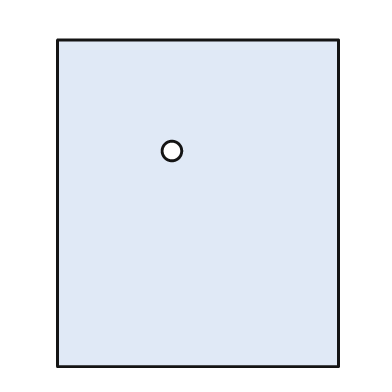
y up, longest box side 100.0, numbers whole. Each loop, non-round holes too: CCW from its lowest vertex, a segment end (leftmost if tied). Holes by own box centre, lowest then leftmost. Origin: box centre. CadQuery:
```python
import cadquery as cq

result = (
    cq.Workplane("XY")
    .moveTo(-43.0, -50.0)
    .lineTo(43.0, -50.0)
    .lineTo(43.0, 50.0)
    .lineTo(-43.0, 50.0)
    .close()
    .moveTo(-8.0, 16.0)
    .circle(3.0)
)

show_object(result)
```